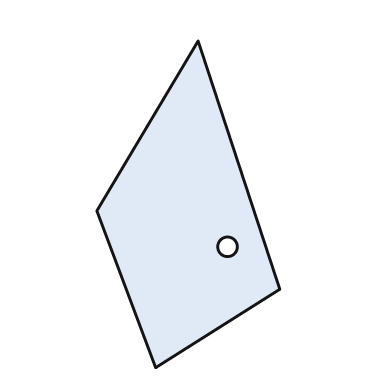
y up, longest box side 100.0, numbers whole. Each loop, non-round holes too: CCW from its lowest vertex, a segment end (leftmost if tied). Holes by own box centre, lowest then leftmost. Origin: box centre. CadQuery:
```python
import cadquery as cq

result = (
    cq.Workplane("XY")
    .moveTo(-10.0, -50.0)
    .lineTo(28.0, -26.0)
    .lineTo(3.0, 50.0)
    .lineTo(-28.0, -2.0)
    .close()
    .moveTo(12.0, -13.0)
    .circle(3.0)
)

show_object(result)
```